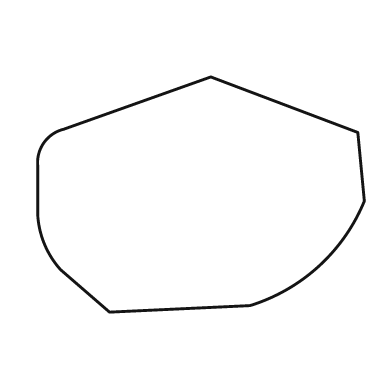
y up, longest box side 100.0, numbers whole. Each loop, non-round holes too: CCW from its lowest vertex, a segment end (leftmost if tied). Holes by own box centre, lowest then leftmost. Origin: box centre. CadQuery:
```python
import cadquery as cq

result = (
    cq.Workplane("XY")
    .moveTo(-28.0, -36.0)
    .lineTo(15.0, -34.0)
    .threePointArc((36.0, -22.0), (50.0, -2.0))
    .lineTo(48.0, 19.0)
    .lineTo(3.0, 36.0)
    .lineTo(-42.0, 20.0)
    .threePointArc((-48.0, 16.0), (-50.0, 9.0))
    .lineTo(-50.0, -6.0)
    .threePointArc((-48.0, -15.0), (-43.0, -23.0))
    .close()
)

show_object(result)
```